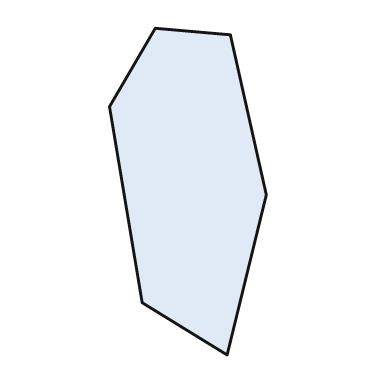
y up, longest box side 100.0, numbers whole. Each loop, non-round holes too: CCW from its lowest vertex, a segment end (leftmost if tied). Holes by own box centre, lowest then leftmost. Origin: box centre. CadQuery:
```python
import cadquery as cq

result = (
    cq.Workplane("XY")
    .moveTo(12.0, -50.0)
    .lineTo(24.0, -1.0)
    .lineTo(13.0, 48.0)
    .lineTo(-10.0, 50.0)
    .lineTo(-24.0, 26.0)
    .lineTo(-14.0, -34.0)
    .close()
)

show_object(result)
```